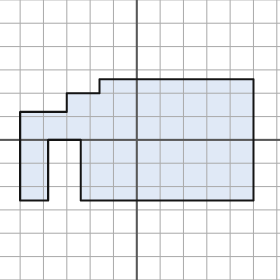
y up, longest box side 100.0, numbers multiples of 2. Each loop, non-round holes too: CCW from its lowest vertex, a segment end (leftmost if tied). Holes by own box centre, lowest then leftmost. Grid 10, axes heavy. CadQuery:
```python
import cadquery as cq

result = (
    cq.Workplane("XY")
    .moveTo(-50.0, -26.0)
    .lineTo(-38.0, -26.0)
    .lineTo(-38.0, 0.0)
    .lineTo(-24.0, 0.0)
    .lineTo(-24.0, -26.0)
    .lineTo(50.0, -26.0)
    .lineTo(50.0, 26.0)
    .lineTo(-16.0, 26.0)
    .lineTo(-16.0, 20.0)
    .lineTo(-30.0, 20.0)
    .lineTo(-30.0, 12.0)
    .lineTo(-50.0, 12.0)
    .close()
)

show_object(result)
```